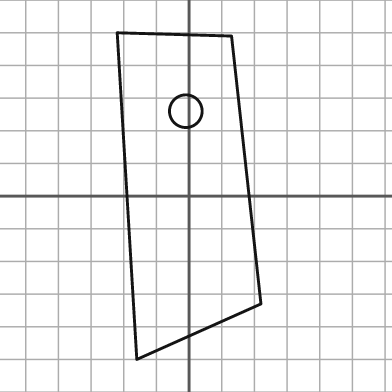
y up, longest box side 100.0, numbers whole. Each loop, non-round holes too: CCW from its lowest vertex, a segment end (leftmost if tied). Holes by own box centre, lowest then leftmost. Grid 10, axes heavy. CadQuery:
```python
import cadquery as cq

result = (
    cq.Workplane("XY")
    .moveTo(-16.0, -50.0)
    .lineTo(22.0, -33.0)
    .lineTo(13.0, 49.0)
    .lineTo(-22.0, 50.0)
    .close()
    .moveTo(-1.0, 26.0)
    .circle(5.0)
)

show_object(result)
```